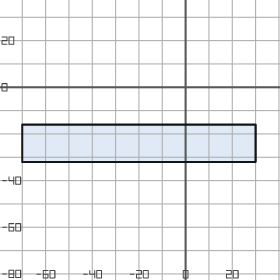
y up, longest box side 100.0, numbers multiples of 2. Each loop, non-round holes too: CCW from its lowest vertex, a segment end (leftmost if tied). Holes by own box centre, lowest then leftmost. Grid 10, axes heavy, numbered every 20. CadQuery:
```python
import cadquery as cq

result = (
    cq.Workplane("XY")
    .moveTo(-70.0, -32.0)
    .lineTo(30.0, -32.0)
    .lineTo(30.0, -16.0)
    .lineTo(-70.0, -16.0)
    .close()
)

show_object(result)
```